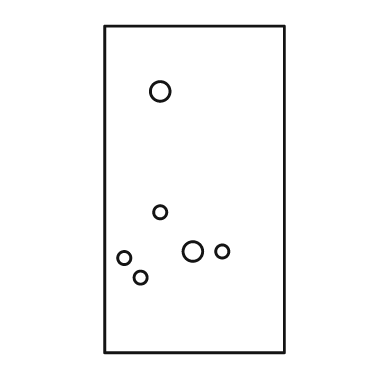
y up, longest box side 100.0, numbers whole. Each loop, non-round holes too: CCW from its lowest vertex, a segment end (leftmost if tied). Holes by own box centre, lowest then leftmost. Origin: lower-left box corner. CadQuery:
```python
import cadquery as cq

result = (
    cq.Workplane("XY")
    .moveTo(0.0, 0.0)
    .lineTo(55.0, 0.0)
    .lineTo(55.0, 100.0)
    .lineTo(0.0, 100.0)
    .close()
    .moveTo(11.0, 23.0)
    .circle(2.0)
    .moveTo(6.0, 29.0)
    .circle(2.0)
    .moveTo(27.0, 31.0)
    .circle(3.0)
    .moveTo(36.0, 31.0)
    .circle(2.0)
    .moveTo(17.0, 43.0)
    .circle(2.0)
    .moveTo(17.0, 80.0)
    .circle(3.0)
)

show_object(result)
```